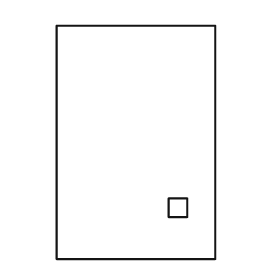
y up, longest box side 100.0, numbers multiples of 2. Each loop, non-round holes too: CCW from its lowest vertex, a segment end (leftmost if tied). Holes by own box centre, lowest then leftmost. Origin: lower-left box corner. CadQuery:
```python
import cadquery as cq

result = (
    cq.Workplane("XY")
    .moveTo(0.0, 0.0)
    .lineTo(68.0, 0.0)
    .lineTo(68.0, 100.0)
    .lineTo(0.0, 100.0)
    .close()
    .moveTo(48.0, 18.0)
    .lineTo(56.0, 18.0)
    .lineTo(56.0, 26.0)
    .lineTo(48.0, 26.0)
    .close()
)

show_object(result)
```